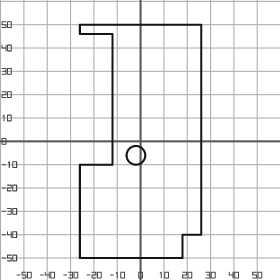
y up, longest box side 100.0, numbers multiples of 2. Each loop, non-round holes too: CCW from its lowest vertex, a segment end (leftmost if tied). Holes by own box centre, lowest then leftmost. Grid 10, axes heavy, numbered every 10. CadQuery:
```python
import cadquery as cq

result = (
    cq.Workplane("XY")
    .moveTo(-26.0, -50.0)
    .lineTo(18.0, -50.0)
    .lineTo(18.0, -40.0)
    .lineTo(26.0, -40.0)
    .lineTo(26.0, 50.0)
    .lineTo(-26.0, 50.0)
    .lineTo(-26.0, 46.0)
    .lineTo(-12.0, 46.0)
    .lineTo(-12.0, -10.0)
    .lineTo(-26.0, -10.0)
    .close()
    .moveTo(-2.0, -6.0)
    .circle(4.0)
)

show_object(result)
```